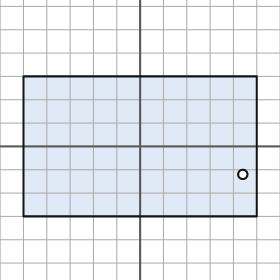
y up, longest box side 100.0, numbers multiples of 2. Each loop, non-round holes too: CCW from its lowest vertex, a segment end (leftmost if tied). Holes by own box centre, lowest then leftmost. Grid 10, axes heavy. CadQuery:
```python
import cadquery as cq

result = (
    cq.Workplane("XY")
    .moveTo(-50.0, -30.0)
    .lineTo(50.0, -30.0)
    .lineTo(50.0, 30.0)
    .lineTo(-50.0, 30.0)
    .close()
    .moveTo(44.0, -12.0)
    .circle(2.0)
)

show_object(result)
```